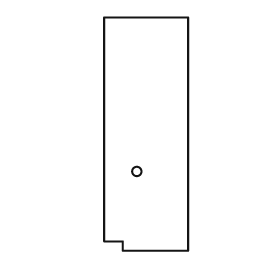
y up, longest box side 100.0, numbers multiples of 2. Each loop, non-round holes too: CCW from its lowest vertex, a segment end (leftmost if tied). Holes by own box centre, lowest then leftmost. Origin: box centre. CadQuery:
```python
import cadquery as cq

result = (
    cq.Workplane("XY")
    .moveTo(-10.0, -50.0)
    .lineTo(18.0, -50.0)
    .lineTo(18.0, 50.0)
    .lineTo(-18.0, 50.0)
    .lineTo(-18.0, -46.0)
    .lineTo(-10.0, -46.0)
    .close()
    .moveTo(-4.0, -16.0)
    .circle(2.0)
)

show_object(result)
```